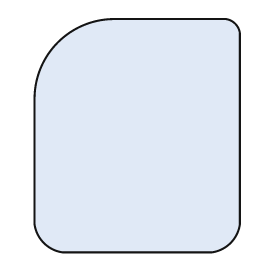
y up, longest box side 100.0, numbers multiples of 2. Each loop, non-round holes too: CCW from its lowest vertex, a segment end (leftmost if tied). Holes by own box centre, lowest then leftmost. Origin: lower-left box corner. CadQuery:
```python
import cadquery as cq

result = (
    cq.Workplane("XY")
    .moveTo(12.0, 0.0)
    .lineTo(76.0, 0.0)
    .threePointArc((84.0, 4.0), (88.0, 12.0))
    .lineTo(88.0, 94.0)
    .threePointArc((86.0, 98.0), (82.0, 100.0))
    .lineTo(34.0, 100.0)
    .threePointArc((10.0, 90.0), (0.0, 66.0))
    .lineTo(0.0, 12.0)
    .threePointArc((4.0, 4.0), (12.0, 0.0))
    .close()
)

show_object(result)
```